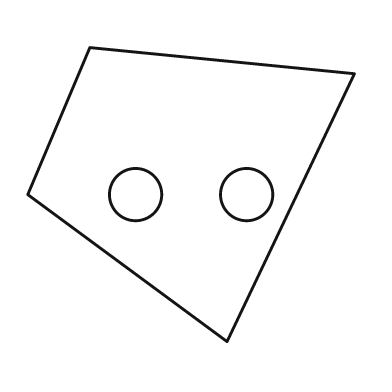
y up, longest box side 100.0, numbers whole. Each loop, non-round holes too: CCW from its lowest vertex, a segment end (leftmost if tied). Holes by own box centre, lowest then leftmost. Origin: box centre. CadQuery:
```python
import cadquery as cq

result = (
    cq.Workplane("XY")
    .moveTo(11.0, -45.0)
    .lineTo(50.0, 37.0)
    .lineTo(-31.0, 45.0)
    .lineTo(-50.0, 0.0)
    .close()
    .moveTo(-17.0, 0.0)
    .circle(8.0)
    .moveTo(17.0, 0.0)
    .circle(8.0)
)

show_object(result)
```